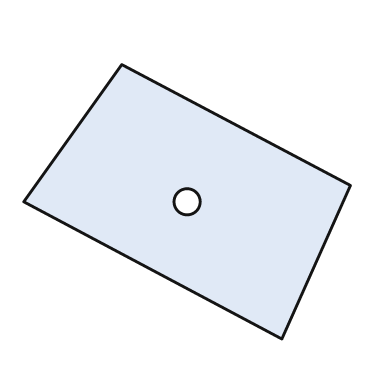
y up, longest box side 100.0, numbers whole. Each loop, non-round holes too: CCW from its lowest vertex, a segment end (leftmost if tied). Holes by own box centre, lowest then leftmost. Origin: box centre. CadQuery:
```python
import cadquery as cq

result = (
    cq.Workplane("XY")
    .moveTo(29.0, -42.0)
    .lineTo(50.0, 5.0)
    .lineTo(-20.0, 42.0)
    .lineTo(-50.0, 0.0)
    .close()
    .moveTo(0.0, 0.0)
    .circle(4.0)
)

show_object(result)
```